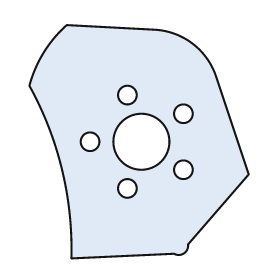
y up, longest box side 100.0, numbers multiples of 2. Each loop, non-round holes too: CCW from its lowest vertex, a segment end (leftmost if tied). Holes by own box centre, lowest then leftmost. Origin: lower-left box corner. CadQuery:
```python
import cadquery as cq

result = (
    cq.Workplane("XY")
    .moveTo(18.0, 0.0)
    .lineTo(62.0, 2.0)
    .threePointArc((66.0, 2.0), (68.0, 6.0))
    .lineTo(94.0, 36.0)
    .lineTo(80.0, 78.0)
    .threePointArc((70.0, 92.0), (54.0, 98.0))
    .lineTo(16.0, 100.0)
    .threePointArc((6.0, 88.0), (0.0, 74.0))
    .threePointArc((14.0, 38.0), (18.0, 0.0))
    .close()
    .moveTo(42.0, 30.0)
    .circle(4.0)
    .moveTo(66.0, 38.0)
    .circle(4.0)
    .moveTo(26.0, 50.0)
    .circle(4.0)
    .moveTo(48.0, 50.0)
    .circle(12.0)
    .moveTo(66.0, 62.0)
    .circle(4.0)
    .moveTo(42.0, 70.0)
    .circle(4.0)
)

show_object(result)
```